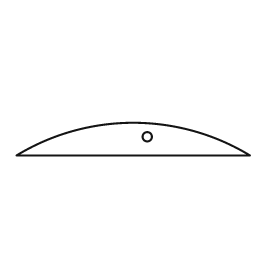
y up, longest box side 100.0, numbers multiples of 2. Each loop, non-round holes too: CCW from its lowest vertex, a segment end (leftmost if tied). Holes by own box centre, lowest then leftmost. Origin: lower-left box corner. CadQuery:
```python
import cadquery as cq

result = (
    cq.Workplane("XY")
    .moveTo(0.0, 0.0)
    .lineTo(100.0, 0.0)
    .threePointArc((50.0, 14.0), (0.0, 0.0))
    .close()
    .moveTo(56.0, 8.0)
    .circle(2.0)
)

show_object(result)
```